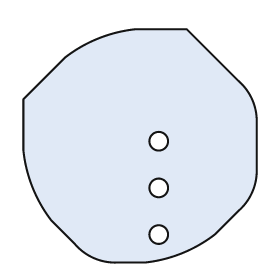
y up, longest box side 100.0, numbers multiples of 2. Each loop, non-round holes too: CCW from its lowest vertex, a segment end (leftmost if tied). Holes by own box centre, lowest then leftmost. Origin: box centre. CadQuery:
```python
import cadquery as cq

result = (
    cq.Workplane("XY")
    .moveTo(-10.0, -50.0)
    .lineTo(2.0, -50.0)
    .threePointArc((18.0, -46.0), (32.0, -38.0))
    .lineTo(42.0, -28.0)
    .threePointArc((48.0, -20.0), (50.0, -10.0))
    .lineTo(50.0, 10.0)
    .threePointArc((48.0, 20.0), (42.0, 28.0))
    .lineTo(20.0, 50.0)
    .lineTo(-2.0, 50.0)
    .threePointArc((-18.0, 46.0), (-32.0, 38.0))
    .lineTo(-50.0, 20.0)
    .lineTo(-50.0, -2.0)
    .threePointArc((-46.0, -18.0), (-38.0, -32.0))
    .lineTo(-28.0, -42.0)
    .threePointArc((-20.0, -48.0), (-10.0, -50.0))
    .close()
    .moveTo(8.0, -38.0)
    .circle(4.0)
    .moveTo(8.0, -18.0)
    .circle(4.0)
    .moveTo(8.0, 2.0)
    .circle(4.0)
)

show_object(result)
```